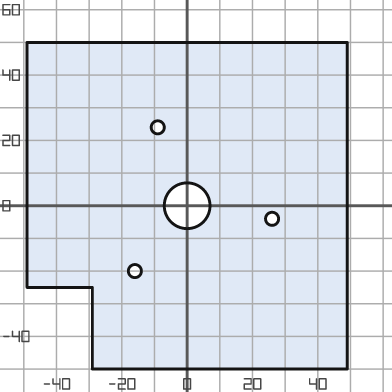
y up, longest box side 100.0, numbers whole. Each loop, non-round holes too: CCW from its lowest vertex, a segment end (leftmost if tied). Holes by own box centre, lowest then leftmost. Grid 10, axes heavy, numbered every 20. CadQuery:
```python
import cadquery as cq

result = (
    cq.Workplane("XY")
    .moveTo(-29.0, -50.0)
    .lineTo(49.0, -50.0)
    .lineTo(49.0, 50.0)
    .lineTo(-49.0, 50.0)
    .lineTo(-49.0, -25.0)
    .lineTo(-29.0, -25.0)
    .close()
    .moveTo(-16.0, -20.0)
    .circle(2.0)
    .moveTo(26.0, -4.0)
    .circle(2.0)
    .moveTo(0.0, 0.0)
    .circle(7.0)
    .moveTo(-9.0, 24.0)
    .circle(2.0)
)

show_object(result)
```